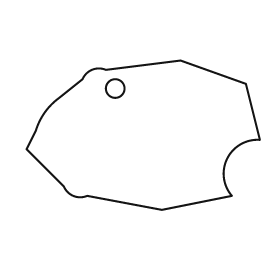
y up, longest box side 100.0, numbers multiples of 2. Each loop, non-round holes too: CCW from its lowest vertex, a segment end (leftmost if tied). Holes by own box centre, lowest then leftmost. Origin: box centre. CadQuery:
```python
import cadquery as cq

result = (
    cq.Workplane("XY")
    .moveTo(8.0, -32.0)
    .lineTo(38.0, -26.0)
    .threePointArc((36.0, -10.0), (50.0, -2.0))
    .lineTo(44.0, 22.0)
    .lineTo(16.0, 32.0)
    .lineTo(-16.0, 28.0)
    .threePointArc((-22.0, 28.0), (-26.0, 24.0))
    .lineTo(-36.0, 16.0)
    .threePointArc((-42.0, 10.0), (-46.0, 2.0))
    .lineTo(-50.0, -6.0)
    .lineTo(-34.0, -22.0)
    .threePointArc((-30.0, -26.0), (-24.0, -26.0))
    .close()
    .moveTo(-12.0, 20.0)
    .circle(4.0)
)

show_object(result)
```